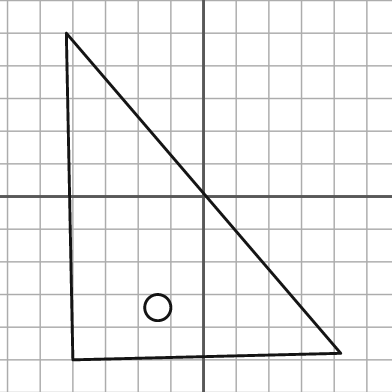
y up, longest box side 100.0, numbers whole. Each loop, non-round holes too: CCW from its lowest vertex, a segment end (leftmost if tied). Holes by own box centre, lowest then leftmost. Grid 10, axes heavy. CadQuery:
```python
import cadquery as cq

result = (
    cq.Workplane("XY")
    .moveTo(-40.0, -50.0)
    .lineTo(42.0, -48.0)
    .lineTo(-42.0, 50.0)
    .close()
    .moveTo(-14.0, -34.0)
    .circle(4.0)
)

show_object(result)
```